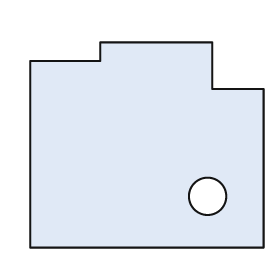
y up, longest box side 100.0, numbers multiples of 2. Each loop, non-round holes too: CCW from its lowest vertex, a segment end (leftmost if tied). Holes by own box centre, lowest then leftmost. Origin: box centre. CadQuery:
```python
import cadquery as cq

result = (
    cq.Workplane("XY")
    .moveTo(-50.0, -44.0)
    .lineTo(50.0, -44.0)
    .lineTo(50.0, 24.0)
    .lineTo(28.0, 24.0)
    .lineTo(28.0, 44.0)
    .lineTo(-20.0, 44.0)
    .lineTo(-20.0, 36.0)
    .lineTo(-50.0, 36.0)
    .close()
    .moveTo(26.0, -22.0)
    .circle(8.0)
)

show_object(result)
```